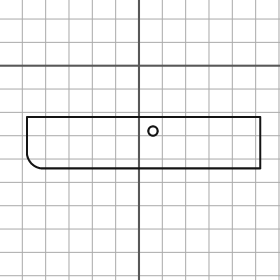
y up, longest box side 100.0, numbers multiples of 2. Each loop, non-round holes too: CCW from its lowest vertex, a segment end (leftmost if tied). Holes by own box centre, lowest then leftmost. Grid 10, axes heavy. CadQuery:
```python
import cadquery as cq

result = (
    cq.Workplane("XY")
    .moveTo(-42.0, -44.0)
    .lineTo(52.0, -44.0)
    .lineTo(52.0, -22.0)
    .lineTo(-48.0, -22.0)
    .lineTo(-48.0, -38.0)
    .threePointArc((-46.0, -42.0), (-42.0, -44.0))
    .close()
    .moveTo(6.0, -28.0)
    .circle(2.0)
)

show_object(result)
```